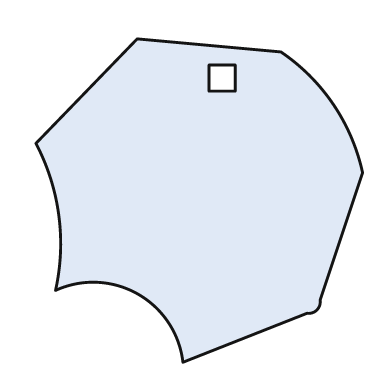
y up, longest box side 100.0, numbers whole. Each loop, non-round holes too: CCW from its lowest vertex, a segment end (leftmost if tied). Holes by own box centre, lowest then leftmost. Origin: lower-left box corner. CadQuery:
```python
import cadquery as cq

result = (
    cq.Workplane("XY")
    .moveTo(45.0, 0.0)
    .lineTo(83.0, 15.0)
    .threePointArc((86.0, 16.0), (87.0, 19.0))
    .lineTo(100.0, 58.0)
    .threePointArc((91.0, 79.0), (75.0, 95.0))
    .lineTo(31.0, 99.0)
    .lineTo(0.0, 67.0)
    .threePointArc((7.0, 45.0), (6.0, 22.0))
    .threePointArc((31.0, 21.0), (45.0, 0.0))
    .close()
    .moveTo(53.0, 83.0)
    .lineTo(61.0, 83.0)
    .lineTo(61.0, 91.0)
    .lineTo(53.0, 91.0)
    .close()
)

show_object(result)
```